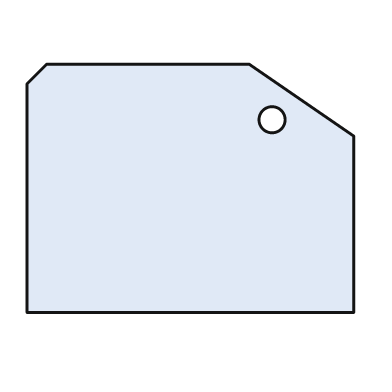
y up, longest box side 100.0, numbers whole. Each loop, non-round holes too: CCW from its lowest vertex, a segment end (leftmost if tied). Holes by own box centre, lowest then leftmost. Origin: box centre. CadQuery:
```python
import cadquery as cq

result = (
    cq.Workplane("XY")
    .moveTo(-50.0, -38.0)
    .lineTo(50.0, -38.0)
    .lineTo(50.0, 16.0)
    .lineTo(18.0, 38.0)
    .lineTo(-44.0, 38.0)
    .lineTo(-50.0, 32.0)
    .close()
    .moveTo(25.0, 21.0)
    .circle(4.0)
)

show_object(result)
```